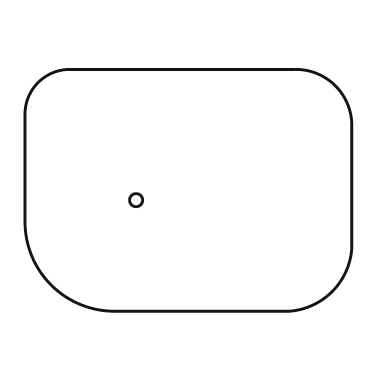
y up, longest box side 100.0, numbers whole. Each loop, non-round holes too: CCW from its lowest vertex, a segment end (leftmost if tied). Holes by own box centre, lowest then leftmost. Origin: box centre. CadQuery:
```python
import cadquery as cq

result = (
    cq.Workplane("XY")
    .moveTo(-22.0, -37.0)
    .lineTo(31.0, -37.0)
    .threePointArc((44.0, -31.0), (50.0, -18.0))
    .lineTo(50.0, 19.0)
    .threePointArc((45.0, 32.0), (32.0, 37.0))
    .lineTo(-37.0, 37.0)
    .threePointArc((-46.0, 33.0), (-50.0, 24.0))
    .lineTo(-50.0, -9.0)
    .threePointArc((-42.0, -29.0), (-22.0, -37.0))
    .close()
    .moveTo(-16.0, -3.0)
    .circle(2.0)
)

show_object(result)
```